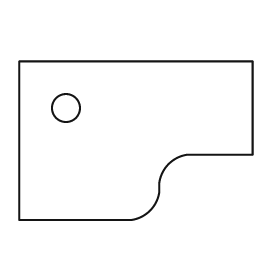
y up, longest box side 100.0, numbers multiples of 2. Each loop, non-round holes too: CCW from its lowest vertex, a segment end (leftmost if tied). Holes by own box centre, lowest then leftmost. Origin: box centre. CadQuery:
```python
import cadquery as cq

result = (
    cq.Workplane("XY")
    .moveTo(-50.0, -34.0)
    .lineTo(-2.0, -34.0)
    .threePointArc((6.0, -30.0), (10.0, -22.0))
    .lineTo(10.0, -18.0)
    .threePointArc((14.0, -10.0), (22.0, -6.0))
    .lineTo(50.0, -6.0)
    .lineTo(50.0, 34.0)
    .lineTo(-50.0, 34.0)
    .close()
    .moveTo(-30.0, 14.0)
    .circle(6.0)
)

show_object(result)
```